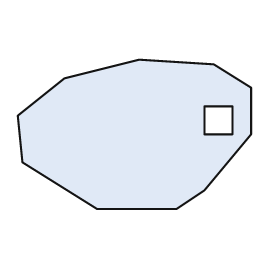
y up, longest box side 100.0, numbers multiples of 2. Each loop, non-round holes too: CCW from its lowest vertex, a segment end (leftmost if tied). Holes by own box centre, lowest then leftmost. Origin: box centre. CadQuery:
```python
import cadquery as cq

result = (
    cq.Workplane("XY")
    .moveTo(-16.0, -32.0)
    .lineTo(18.0, -32.0)
    .lineTo(30.0, -24.0)
    .lineTo(50.0, 0.0)
    .lineTo(50.0, 20.0)
    .lineTo(34.0, 30.0)
    .lineTo(2.0, 32.0)
    .lineTo(-30.0, 24.0)
    .lineTo(-50.0, 8.0)
    .lineTo(-48.0, -12.0)
    .close()
    .moveTo(30.0, 0.0)
    .lineTo(42.0, 0.0)
    .lineTo(42.0, 12.0)
    .lineTo(30.0, 12.0)
    .close()
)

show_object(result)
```